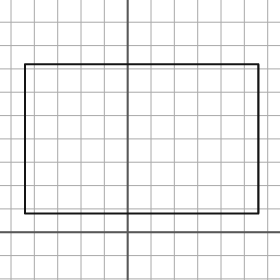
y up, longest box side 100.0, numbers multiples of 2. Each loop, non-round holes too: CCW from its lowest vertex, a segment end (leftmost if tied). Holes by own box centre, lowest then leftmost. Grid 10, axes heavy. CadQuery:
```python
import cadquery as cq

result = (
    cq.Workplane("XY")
    .moveTo(-44.0, 8.0)
    .lineTo(56.0, 8.0)
    .lineTo(56.0, 72.0)
    .lineTo(-44.0, 72.0)
    .close()
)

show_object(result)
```